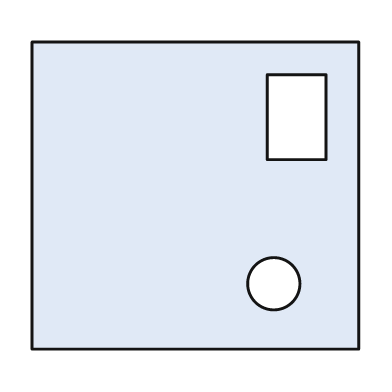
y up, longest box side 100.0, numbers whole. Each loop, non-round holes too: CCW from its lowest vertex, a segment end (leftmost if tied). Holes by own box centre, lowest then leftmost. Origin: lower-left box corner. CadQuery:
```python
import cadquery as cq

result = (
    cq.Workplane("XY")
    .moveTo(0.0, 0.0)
    .lineTo(100.0, 0.0)
    .lineTo(100.0, 94.0)
    .lineTo(0.0, 94.0)
    .close()
    .moveTo(74.0, 20.0)
    .circle(8.0)
    .moveTo(72.0, 58.0)
    .lineTo(90.0, 58.0)
    .lineTo(90.0, 84.0)
    .lineTo(72.0, 84.0)
    .close()
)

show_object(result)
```